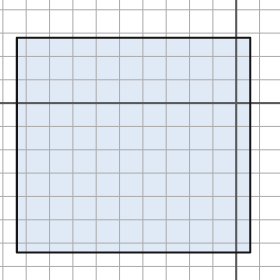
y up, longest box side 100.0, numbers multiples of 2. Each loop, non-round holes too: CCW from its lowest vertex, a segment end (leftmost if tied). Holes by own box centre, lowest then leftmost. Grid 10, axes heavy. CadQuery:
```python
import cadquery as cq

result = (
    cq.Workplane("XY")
    .moveTo(-94.0, -64.0)
    .lineTo(6.0, -64.0)
    .lineTo(6.0, 28.0)
    .lineTo(-94.0, 28.0)
    .close()
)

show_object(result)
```